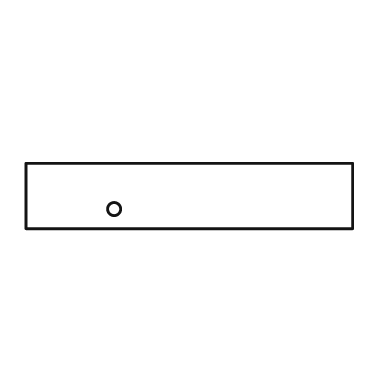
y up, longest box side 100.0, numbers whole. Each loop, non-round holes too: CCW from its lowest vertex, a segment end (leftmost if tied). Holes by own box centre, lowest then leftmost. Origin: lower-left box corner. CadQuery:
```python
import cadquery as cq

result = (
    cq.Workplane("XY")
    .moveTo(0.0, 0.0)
    .lineTo(100.0, 0.0)
    .lineTo(100.0, 20.0)
    .lineTo(0.0, 20.0)
    .close()
    .moveTo(27.0, 6.0)
    .circle(2.0)
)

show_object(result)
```